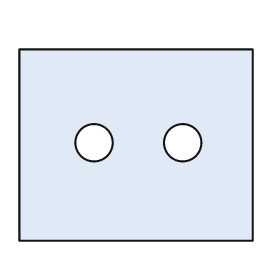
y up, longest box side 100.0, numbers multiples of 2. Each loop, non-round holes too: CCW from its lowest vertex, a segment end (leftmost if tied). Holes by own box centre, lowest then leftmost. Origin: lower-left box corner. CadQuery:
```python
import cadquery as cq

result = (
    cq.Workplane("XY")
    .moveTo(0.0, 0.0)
    .lineTo(100.0, 0.0)
    .lineTo(100.0, 82.0)
    .lineTo(0.0, 82.0)
    .close()
    .moveTo(32.0, 42.0)
    .circle(8.0)
    .moveTo(70.0, 42.0)
    .circle(8.0)
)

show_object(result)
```